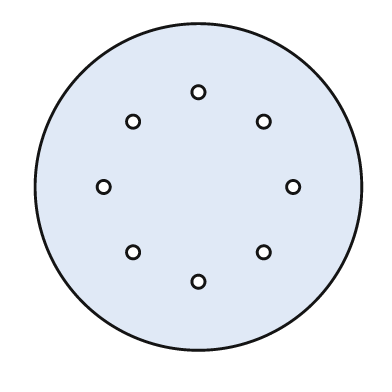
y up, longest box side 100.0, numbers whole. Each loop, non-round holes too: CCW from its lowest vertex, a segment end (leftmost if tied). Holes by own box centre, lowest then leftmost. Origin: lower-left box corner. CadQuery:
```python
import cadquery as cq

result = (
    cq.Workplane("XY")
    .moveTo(50.0, 50.0)
    .circle(50.0)
    .moveTo(50.0, 21.0)
    .circle(2.0)
    .moveTo(30.0, 30.0)
    .circle(2.0)
    .moveTo(70.0, 30.0)
    .circle(2.0)
    .moveTo(21.0, 50.0)
    .circle(2.0)
    .moveTo(79.0, 50.0)
    .circle(2.0)
    .moveTo(30.0, 70.0)
    .circle(2.0)
    .moveTo(70.0, 70.0)
    .circle(2.0)
    .moveTo(50.0, 79.0)
    .circle(2.0)
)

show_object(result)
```